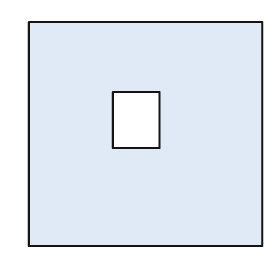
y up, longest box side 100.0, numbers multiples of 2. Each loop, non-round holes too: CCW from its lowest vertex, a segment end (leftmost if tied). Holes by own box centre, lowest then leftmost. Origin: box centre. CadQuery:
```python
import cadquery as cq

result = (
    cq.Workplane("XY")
    .moveTo(-50.0, -48.0)
    .lineTo(50.0, -48.0)
    .lineTo(50.0, 48.0)
    .lineTo(-50.0, 48.0)
    .close()
    .moveTo(-14.0, -6.0)
    .lineTo(6.0, -6.0)
    .lineTo(6.0, 18.0)
    .lineTo(-14.0, 18.0)
    .close()
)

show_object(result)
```